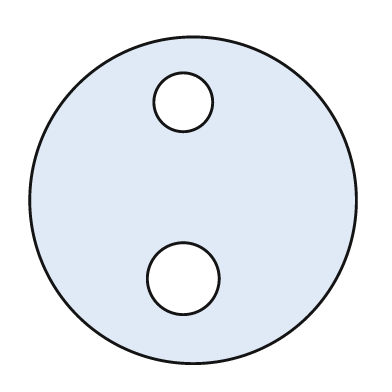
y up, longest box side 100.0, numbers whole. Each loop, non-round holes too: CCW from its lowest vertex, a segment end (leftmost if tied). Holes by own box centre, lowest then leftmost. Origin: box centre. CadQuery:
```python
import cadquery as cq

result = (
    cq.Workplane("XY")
    .moveTo(0.0, 0.0)
    .circle(50.0)
    .moveTo(-3.0, -24.0)
    .circle(11.0)
    .moveTo(-3.0, 30.0)
    .circle(9.0)
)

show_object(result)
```